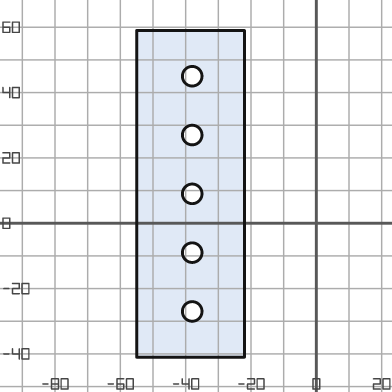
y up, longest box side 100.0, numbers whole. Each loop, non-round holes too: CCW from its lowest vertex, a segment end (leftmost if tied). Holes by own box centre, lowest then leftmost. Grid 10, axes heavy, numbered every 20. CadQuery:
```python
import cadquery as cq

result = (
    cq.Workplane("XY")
    .moveTo(-55.0, -41.0)
    .lineTo(-22.0, -41.0)
    .lineTo(-22.0, 59.0)
    .lineTo(-55.0, 59.0)
    .close()
    .moveTo(-38.0, -27.0)
    .circle(3.0)
    .moveTo(-38.0, -9.0)
    .circle(3.0)
    .moveTo(-38.0, 9.0)
    .circle(3.0)
    .moveTo(-38.0, 27.0)
    .circle(3.0)
    .moveTo(-38.0, 45.0)
    .circle(3.0)
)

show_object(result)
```